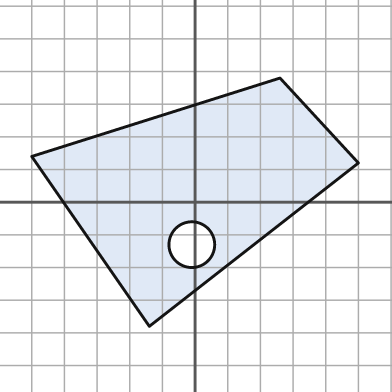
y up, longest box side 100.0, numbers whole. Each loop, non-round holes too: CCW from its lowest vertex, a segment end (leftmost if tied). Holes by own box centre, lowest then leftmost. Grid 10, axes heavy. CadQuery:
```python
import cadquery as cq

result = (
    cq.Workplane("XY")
    .moveTo(-14.0, -38.0)
    .lineTo(50.0, 12.0)
    .lineTo(26.0, 38.0)
    .lineTo(-50.0, 14.0)
    .close()
    .moveTo(-1.0, -13.0)
    .circle(7.0)
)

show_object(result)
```